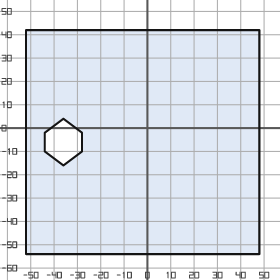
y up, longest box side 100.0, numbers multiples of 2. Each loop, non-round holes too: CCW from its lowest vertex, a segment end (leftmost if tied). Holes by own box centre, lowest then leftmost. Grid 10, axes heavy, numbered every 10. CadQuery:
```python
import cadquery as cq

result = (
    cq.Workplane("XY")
    .moveTo(-52.0, -54.0)
    .lineTo(48.0, -54.0)
    .lineTo(48.0, 42.0)
    .lineTo(-52.0, 42.0)
    .close()
    .moveTo(-36.0, -16.0)
    .lineTo(-28.0, -10.0)
    .lineTo(-28.0, -2.0)
    .lineTo(-36.0, 4.0)
    .lineTo(-44.0, -2.0)
    .lineTo(-44.0, -10.0)
    .close()
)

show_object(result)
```